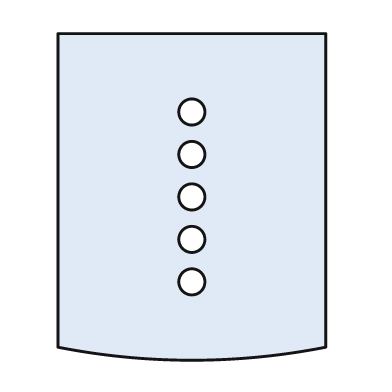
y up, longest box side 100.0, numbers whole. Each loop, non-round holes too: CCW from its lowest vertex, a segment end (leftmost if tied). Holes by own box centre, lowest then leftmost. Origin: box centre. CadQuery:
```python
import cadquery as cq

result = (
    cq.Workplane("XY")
    .moveTo(-41.0, -46.0)
    .threePointArc((0.0, -50.0), (41.0, -46.0))
    .lineTo(41.0, 50.0)
    .lineTo(-41.0, 50.0)
    .close()
    .moveTo(0.0, -26.0)
    .circle(4.0)
    .moveTo(0.0, -13.0)
    .circle(4.0)
    .moveTo(0.0, 0.0)
    .circle(4.0)
    .moveTo(0.0, 13.0)
    .circle(4.0)
    .moveTo(0.0, 26.0)
    .circle(4.0)
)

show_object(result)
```